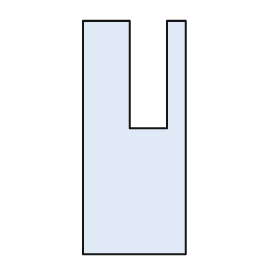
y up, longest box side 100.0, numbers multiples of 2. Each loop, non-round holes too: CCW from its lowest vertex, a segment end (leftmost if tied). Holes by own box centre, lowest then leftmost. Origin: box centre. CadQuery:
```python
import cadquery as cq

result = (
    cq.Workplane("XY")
    .moveTo(-22.0, -50.0)
    .lineTo(22.0, -50.0)
    .lineTo(22.0, 50.0)
    .lineTo(14.0, 50.0)
    .lineTo(14.0, 4.0)
    .lineTo(-2.0, 4.0)
    .lineTo(-2.0, 50.0)
    .lineTo(-22.0, 50.0)
    .close()
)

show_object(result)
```